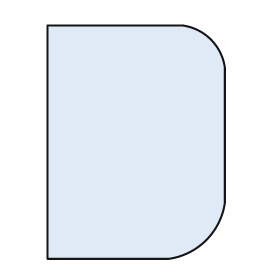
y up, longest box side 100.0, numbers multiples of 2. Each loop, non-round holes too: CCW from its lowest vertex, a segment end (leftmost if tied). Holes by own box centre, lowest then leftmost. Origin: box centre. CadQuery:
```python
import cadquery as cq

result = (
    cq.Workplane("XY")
    .moveTo(-38.0, -50.0)
    .lineTo(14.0, -50.0)
    .threePointArc((30.0, -42.0), (38.0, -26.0))
    .lineTo(38.0, 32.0)
    .threePointArc((32.0, 44.0), (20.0, 50.0))
    .lineTo(-38.0, 50.0)
    .close()
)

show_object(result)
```